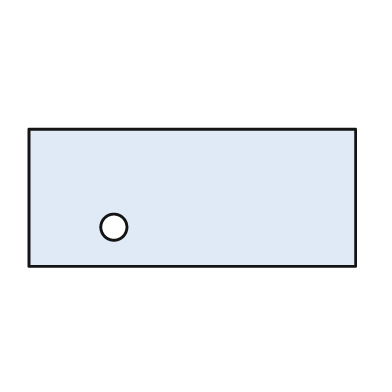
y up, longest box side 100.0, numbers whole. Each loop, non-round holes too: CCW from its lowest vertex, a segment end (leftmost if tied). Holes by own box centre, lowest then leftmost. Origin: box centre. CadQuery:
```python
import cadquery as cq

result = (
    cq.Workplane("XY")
    .moveTo(-50.0, -21.0)
    .lineTo(50.0, -21.0)
    .lineTo(50.0, 21.0)
    .lineTo(-50.0, 21.0)
    .close()
    .moveTo(-24.0, -9.0)
    .circle(4.0)
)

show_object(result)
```